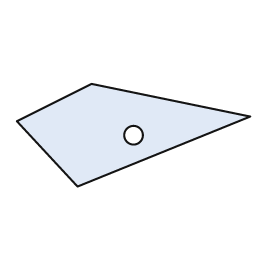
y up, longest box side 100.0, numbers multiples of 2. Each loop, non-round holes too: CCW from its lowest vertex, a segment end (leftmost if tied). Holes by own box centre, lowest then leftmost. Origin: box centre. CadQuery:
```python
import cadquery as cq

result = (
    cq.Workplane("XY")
    .moveTo(-24.0, -22.0)
    .lineTo(50.0, 8.0)
    .lineTo(-18.0, 22.0)
    .lineTo(-50.0, 6.0)
    .close()
    .moveTo(0.0, 0.0)
    .circle(4.0)
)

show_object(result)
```